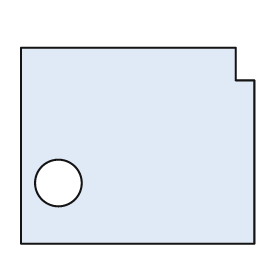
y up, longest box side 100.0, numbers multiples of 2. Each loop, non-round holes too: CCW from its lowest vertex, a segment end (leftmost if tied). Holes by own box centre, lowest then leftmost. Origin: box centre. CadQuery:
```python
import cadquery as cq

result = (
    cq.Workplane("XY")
    .moveTo(-50.0, -42.0)
    .lineTo(50.0, -42.0)
    .lineTo(50.0, 28.0)
    .lineTo(42.0, 28.0)
    .lineTo(42.0, 42.0)
    .lineTo(-50.0, 42.0)
    .close()
    .moveTo(-34.0, -16.0)
    .circle(10.0)
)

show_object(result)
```